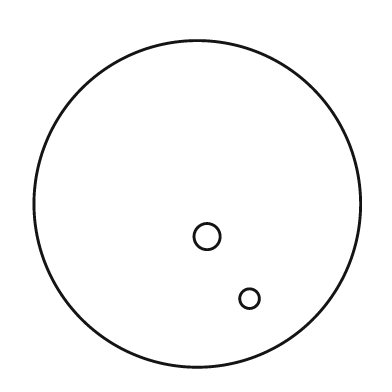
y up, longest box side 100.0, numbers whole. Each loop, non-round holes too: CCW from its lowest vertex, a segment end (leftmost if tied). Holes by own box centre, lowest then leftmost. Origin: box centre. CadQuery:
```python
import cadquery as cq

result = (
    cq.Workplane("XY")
    .moveTo(0.0, 0.0)
    .circle(50.0)
    .moveTo(16.0, -29.0)
    .circle(3.0)
    .moveTo(3.0, -10.0)
    .circle(4.0)
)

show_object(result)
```